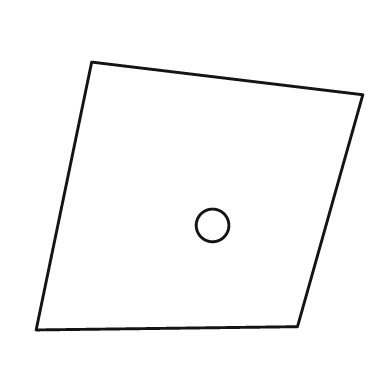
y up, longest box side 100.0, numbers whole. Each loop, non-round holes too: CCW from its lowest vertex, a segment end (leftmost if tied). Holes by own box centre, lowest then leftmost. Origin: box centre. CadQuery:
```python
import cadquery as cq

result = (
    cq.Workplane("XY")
    .moveTo(-50.0, -41.0)
    .lineTo(30.0, -40.0)
    .lineTo(50.0, 31.0)
    .lineTo(-33.0, 41.0)
    .close()
    .moveTo(4.0, -9.0)
    .circle(5.0)
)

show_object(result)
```